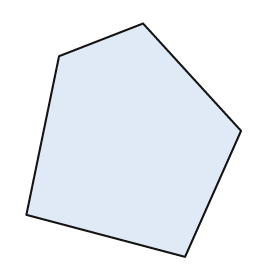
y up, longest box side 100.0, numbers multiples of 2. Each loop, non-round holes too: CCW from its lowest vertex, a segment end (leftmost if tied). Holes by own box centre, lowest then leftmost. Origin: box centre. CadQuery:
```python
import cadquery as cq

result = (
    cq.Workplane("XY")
    .moveTo(22.0, -50.0)
    .lineTo(46.0, 4.0)
    .lineTo(4.0, 50.0)
    .lineTo(-32.0, 36.0)
    .lineTo(-46.0, -32.0)
    .close()
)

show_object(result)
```